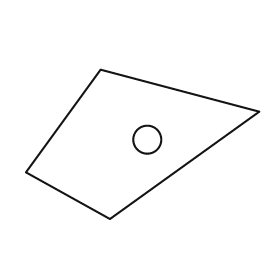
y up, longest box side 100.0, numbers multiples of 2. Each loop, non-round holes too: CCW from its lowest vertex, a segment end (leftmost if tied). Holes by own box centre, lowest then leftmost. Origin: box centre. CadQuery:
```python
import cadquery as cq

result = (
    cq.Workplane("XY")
    .moveTo(-14.0, -32.0)
    .lineTo(50.0, 14.0)
    .lineTo(-18.0, 32.0)
    .lineTo(-50.0, -12.0)
    .close()
    .moveTo(2.0, 2.0)
    .circle(6.0)
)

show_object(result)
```